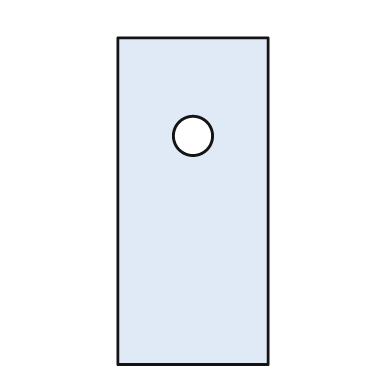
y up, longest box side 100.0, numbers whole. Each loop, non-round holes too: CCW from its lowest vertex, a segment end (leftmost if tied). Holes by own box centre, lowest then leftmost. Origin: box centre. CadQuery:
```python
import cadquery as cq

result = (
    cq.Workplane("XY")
    .moveTo(-23.0, -50.0)
    .lineTo(23.0, -50.0)
    .lineTo(23.0, 50.0)
    .lineTo(-23.0, 50.0)
    .close()
    .moveTo(0.0, 20.0)
    .circle(6.0)
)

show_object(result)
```